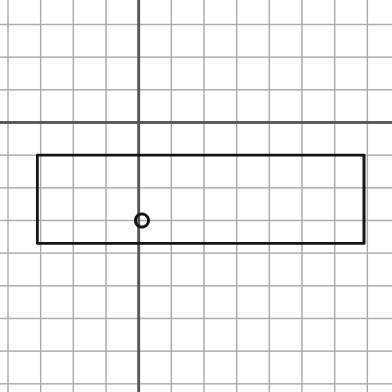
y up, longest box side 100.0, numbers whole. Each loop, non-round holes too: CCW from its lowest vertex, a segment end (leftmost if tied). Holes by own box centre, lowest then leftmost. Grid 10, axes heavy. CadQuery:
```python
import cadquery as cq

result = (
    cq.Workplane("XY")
    .moveTo(-31.0, -37.0)
    .lineTo(69.0, -37.0)
    .lineTo(69.0, -10.0)
    .lineTo(-31.0, -10.0)
    .close()
    .moveTo(1.0, -30.0)
    .circle(2.0)
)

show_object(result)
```